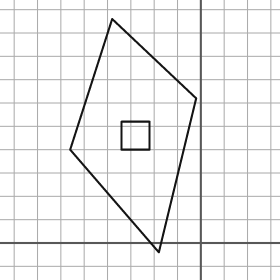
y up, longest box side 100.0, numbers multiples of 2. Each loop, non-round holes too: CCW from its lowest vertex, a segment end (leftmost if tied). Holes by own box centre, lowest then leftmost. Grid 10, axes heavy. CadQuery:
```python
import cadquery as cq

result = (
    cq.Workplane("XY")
    .moveTo(-18.0, -4.0)
    .lineTo(-2.0, 62.0)
    .lineTo(-38.0, 96.0)
    .lineTo(-56.0, 40.0)
    .close()
    .moveTo(-34.0, 40.0)
    .lineTo(-22.0, 40.0)
    .lineTo(-22.0, 52.0)
    .lineTo(-34.0, 52.0)
    .close()
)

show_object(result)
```